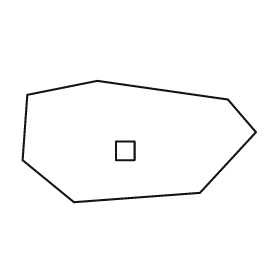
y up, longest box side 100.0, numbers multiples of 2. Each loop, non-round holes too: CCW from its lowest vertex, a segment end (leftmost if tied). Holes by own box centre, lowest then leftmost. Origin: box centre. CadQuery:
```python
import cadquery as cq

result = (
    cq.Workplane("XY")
    .moveTo(-28.0, -26.0)
    .lineTo(26.0, -22.0)
    .lineTo(50.0, 4.0)
    .lineTo(38.0, 18.0)
    .lineTo(-18.0, 26.0)
    .lineTo(-48.0, 20.0)
    .lineTo(-50.0, -8.0)
    .close()
    .moveTo(-10.0, -8.0)
    .lineTo(-2.0, -8.0)
    .lineTo(-2.0, 0.0)
    .lineTo(-10.0, 0.0)
    .close()
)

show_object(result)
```